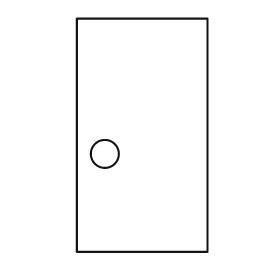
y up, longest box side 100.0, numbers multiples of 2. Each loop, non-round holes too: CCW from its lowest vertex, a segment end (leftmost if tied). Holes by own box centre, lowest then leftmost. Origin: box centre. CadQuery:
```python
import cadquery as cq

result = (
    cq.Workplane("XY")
    .moveTo(-28.0, -50.0)
    .lineTo(28.0, -50.0)
    .lineTo(28.0, 50.0)
    .lineTo(-28.0, 50.0)
    .close()
    .moveTo(-16.0, -8.0)
    .circle(6.0)
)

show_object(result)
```